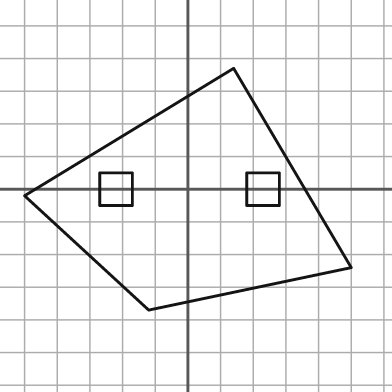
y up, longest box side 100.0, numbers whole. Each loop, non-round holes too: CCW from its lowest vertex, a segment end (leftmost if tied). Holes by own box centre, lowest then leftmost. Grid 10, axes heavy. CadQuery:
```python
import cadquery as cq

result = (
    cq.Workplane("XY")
    .moveTo(-12.0, -37.0)
    .lineTo(50.0, -24.0)
    .lineTo(14.0, 37.0)
    .lineTo(-50.0, -2.0)
    .close()
    .moveTo(-27.0, -5.0)
    .lineTo(-17.0, -5.0)
    .lineTo(-17.0, 5.0)
    .lineTo(-27.0, 5.0)
    .close()
    .moveTo(18.0, -5.0)
    .lineTo(28.0, -5.0)
    .lineTo(28.0, 5.0)
    .lineTo(18.0, 5.0)
    .close()
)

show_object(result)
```